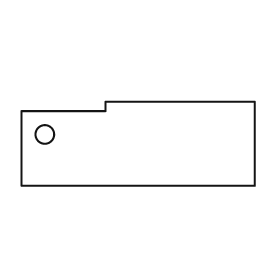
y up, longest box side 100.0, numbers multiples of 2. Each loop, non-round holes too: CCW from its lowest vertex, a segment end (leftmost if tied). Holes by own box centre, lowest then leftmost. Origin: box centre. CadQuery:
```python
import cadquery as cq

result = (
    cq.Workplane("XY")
    .moveTo(-50.0, -18.0)
    .lineTo(50.0, -18.0)
    .lineTo(50.0, 18.0)
    .lineTo(-14.0, 18.0)
    .lineTo(-14.0, 14.0)
    .lineTo(-50.0, 14.0)
    .close()
    .moveTo(-40.0, 4.0)
    .circle(4.0)
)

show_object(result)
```